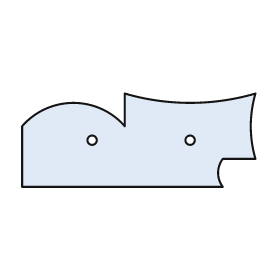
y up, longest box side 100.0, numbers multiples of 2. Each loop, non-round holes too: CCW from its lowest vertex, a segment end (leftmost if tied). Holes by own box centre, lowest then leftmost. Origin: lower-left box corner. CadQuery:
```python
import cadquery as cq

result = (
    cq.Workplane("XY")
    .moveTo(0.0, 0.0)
    .lineTo(86.0, 0.0)
    .threePointArc((84.0, 6.0), (86.0, 12.0))
    .lineTo(100.0, 12.0)
    .threePointArc((98.0, 26.0), (100.0, 40.0))
    .threePointArc((72.0, 36.0), (44.0, 40.0))
    .lineTo(44.0, 26.0)
    .threePointArc((22.0, 36.0), (0.0, 26.0))
    .close()
    .moveTo(30.0, 20.0)
    .circle(2.0)
    .moveTo(72.0, 20.0)
    .circle(2.0)
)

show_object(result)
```